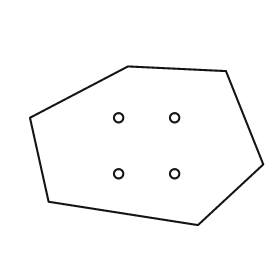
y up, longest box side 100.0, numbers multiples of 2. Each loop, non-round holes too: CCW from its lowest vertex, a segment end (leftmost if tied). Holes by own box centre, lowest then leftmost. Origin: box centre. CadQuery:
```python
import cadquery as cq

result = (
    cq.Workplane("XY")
    .moveTo(22.0, -34.0)
    .lineTo(50.0, -8.0)
    .lineTo(34.0, 32.0)
    .lineTo(-8.0, 34.0)
    .lineTo(-50.0, 12.0)
    .lineTo(-42.0, -24.0)
    .close()
    .moveTo(-12.0, -12.0)
    .circle(2.0)
    .moveTo(12.0, -12.0)
    .circle(2.0)
    .moveTo(-12.0, 12.0)
    .circle(2.0)
    .moveTo(12.0, 12.0)
    .circle(2.0)
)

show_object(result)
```